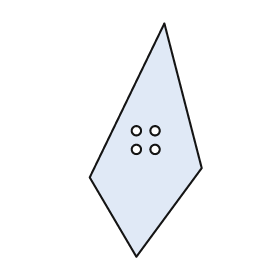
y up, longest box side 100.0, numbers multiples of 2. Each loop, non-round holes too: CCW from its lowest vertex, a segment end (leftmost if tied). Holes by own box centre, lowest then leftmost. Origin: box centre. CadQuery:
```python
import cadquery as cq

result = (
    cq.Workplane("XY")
    .moveTo(-4.0, -50.0)
    .lineTo(24.0, -12.0)
    .lineTo(8.0, 50.0)
    .lineTo(-24.0, -16.0)
    .close()
    .moveTo(-4.0, -4.0)
    .circle(2.0)
    .moveTo(4.0, -4.0)
    .circle(2.0)
    .moveTo(-4.0, 4.0)
    .circle(2.0)
    .moveTo(4.0, 4.0)
    .circle(2.0)
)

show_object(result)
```